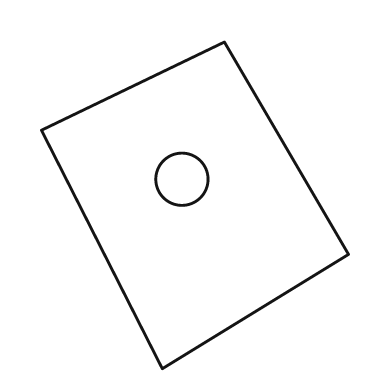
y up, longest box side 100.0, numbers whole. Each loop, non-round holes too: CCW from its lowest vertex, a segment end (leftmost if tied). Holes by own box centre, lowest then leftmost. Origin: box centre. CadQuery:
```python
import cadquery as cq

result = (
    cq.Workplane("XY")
    .moveTo(-10.0, -50.0)
    .lineTo(47.0, -15.0)
    .lineTo(9.0, 50.0)
    .lineTo(-47.0, 23.0)
    .close()
    .moveTo(-4.0, 8.0)
    .circle(8.0)
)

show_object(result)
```